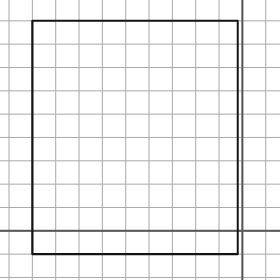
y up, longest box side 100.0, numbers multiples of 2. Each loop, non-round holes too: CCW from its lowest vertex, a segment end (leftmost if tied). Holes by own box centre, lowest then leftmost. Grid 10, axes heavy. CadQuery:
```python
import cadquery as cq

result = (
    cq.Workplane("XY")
    .moveTo(-90.0, -10.0)
    .lineTo(-2.0, -10.0)
    .lineTo(-2.0, 90.0)
    .lineTo(-90.0, 90.0)
    .close()
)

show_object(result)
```